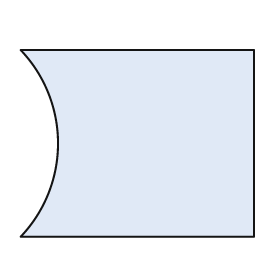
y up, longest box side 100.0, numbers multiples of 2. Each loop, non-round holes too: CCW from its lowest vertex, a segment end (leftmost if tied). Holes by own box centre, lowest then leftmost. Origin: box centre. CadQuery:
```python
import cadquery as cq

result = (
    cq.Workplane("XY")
    .moveTo(-50.0, -40.0)
    .lineTo(50.0, -40.0)
    .lineTo(50.0, 40.0)
    .lineTo(-50.0, 40.0)
    .threePointArc((-34.0, 0.0), (-50.0, -40.0))
    .close()
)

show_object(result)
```